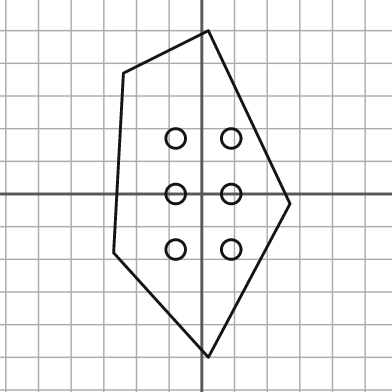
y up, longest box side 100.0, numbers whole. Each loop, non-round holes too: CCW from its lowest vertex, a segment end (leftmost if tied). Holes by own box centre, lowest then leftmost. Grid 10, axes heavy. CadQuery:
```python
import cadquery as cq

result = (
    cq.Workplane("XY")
    .moveTo(2.0, -50.0)
    .lineTo(27.0, -3.0)
    .lineTo(2.0, 50.0)
    .lineTo(-24.0, 37.0)
    .lineTo(-27.0, -18.0)
    .close()
    .moveTo(-8.0, -17.0)
    .circle(3.0)
    .moveTo(9.0, -17.0)
    .circle(3.0)
    .moveTo(-8.0, 0.0)
    .circle(3.0)
    .moveTo(9.0, 0.0)
    .circle(3.0)
    .moveTo(-8.0, 17.0)
    .circle(3.0)
    .moveTo(9.0, 17.0)
    .circle(3.0)
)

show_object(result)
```